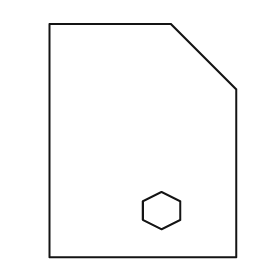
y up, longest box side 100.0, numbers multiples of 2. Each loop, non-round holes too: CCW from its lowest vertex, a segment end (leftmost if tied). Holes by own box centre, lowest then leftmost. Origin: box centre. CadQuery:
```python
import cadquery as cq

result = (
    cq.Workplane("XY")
    .moveTo(-40.0, -50.0)
    .lineTo(40.0, -50.0)
    .lineTo(40.0, 22.0)
    .lineTo(12.0, 50.0)
    .lineTo(-40.0, 50.0)
    .close()
    .moveTo(8.0, -38.0)
    .lineTo(16.0, -34.0)
    .lineTo(16.0, -26.0)
    .lineTo(8.0, -22.0)
    .lineTo(0.0, -26.0)
    .lineTo(0.0, -34.0)
    .close()
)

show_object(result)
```